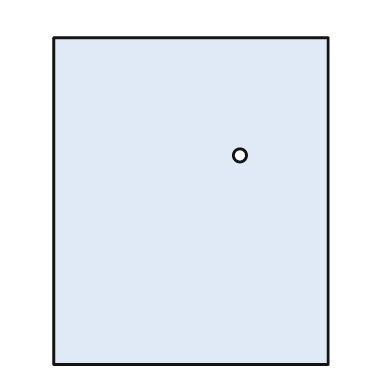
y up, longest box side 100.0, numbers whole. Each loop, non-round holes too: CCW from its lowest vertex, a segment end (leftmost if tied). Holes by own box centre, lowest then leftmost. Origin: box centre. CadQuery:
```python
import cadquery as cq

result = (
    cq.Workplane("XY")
    .moveTo(-42.0, -50.0)
    .lineTo(42.0, -50.0)
    .lineTo(42.0, 50.0)
    .lineTo(-42.0, 50.0)
    .close()
    .moveTo(15.0, 14.0)
    .circle(2.0)
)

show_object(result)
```